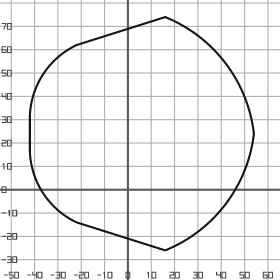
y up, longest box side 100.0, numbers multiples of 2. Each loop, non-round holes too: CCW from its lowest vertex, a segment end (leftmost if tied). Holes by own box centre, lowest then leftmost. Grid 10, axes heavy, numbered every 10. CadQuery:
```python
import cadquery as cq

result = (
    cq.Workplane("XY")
    .moveTo(16.0, -26.0)
    .threePointArc((42.0, -6.0), (54.0, 24.0))
    .threePointArc((42.0, 54.0), (16.0, 74.0))
    .lineTo(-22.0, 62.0)
    .threePointArc((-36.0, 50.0), (-42.0, 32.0))
    .lineTo(-42.0, 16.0)
    .threePointArc((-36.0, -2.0), (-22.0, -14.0))
    .close()
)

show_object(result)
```